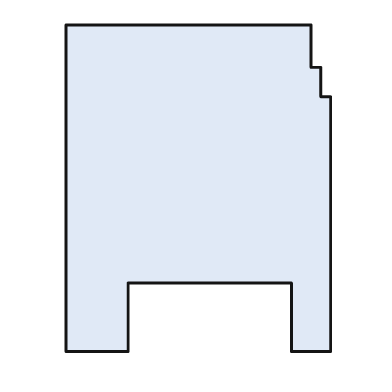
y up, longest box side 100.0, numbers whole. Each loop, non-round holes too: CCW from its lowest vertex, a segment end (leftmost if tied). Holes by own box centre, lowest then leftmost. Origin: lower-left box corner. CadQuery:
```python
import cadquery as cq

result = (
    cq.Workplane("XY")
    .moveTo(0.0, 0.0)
    .lineTo(19.0, 0.0)
    .lineTo(19.0, 21.0)
    .lineTo(69.0, 21.0)
    .lineTo(69.0, 0.0)
    .lineTo(81.0, 0.0)
    .lineTo(81.0, 78.0)
    .lineTo(78.0, 78.0)
    .lineTo(78.0, 87.0)
    .lineTo(75.0, 87.0)
    .lineTo(75.0, 100.0)
    .lineTo(0.0, 100.0)
    .close()
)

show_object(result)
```